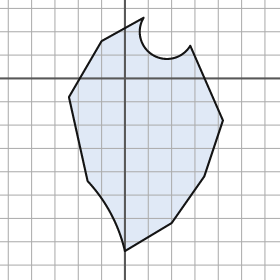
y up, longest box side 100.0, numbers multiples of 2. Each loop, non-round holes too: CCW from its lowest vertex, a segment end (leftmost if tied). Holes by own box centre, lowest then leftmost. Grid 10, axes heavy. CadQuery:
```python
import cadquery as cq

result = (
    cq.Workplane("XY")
    .moveTo(0.0, -74.0)
    .lineTo(20.0, -62.0)
    .lineTo(34.0, -42.0)
    .lineTo(42.0, -18.0)
    .lineTo(28.0, 14.0)
    .threePointArc((12.0, 10.0), (8.0, 26.0))
    .lineTo(-10.0, 16.0)
    .lineTo(-24.0, -8.0)
    .lineTo(-16.0, -44.0)
    .threePointArc((-6.0, -58.0), (0.0, -74.0))
    .close()
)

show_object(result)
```